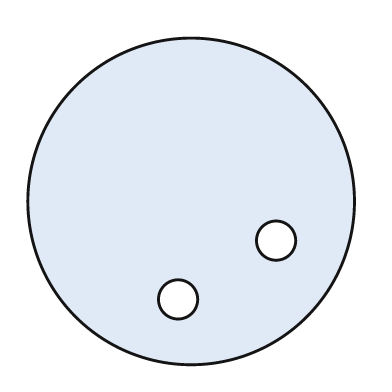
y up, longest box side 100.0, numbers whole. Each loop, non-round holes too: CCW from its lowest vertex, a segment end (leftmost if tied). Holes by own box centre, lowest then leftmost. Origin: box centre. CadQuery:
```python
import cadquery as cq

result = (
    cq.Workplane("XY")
    .moveTo(0.0, 0.0)
    .circle(50.0)
    .moveTo(-4.0, -30.0)
    .circle(6.0)
    .moveTo(26.0, -12.0)
    .circle(6.0)
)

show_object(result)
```